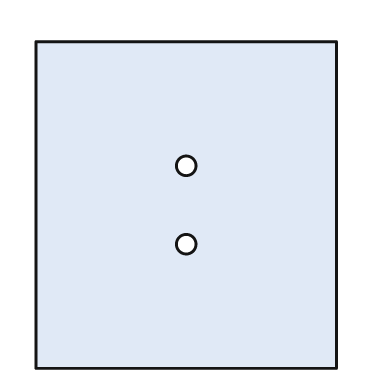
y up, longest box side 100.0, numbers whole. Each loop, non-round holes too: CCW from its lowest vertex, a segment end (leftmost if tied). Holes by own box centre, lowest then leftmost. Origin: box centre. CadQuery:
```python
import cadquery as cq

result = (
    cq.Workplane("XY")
    .moveTo(-46.0, -50.0)
    .lineTo(46.0, -50.0)
    .lineTo(46.0, 50.0)
    .lineTo(-46.0, 50.0)
    .close()
    .moveTo(0.0, -12.0)
    .circle(3.0)
    .moveTo(0.0, 12.0)
    .circle(3.0)
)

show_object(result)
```